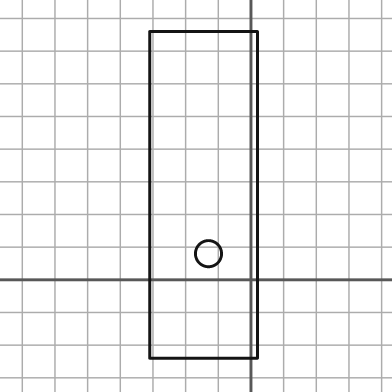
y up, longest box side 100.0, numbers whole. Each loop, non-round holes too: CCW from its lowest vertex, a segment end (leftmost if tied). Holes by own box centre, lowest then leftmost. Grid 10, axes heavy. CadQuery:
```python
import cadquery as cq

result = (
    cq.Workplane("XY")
    .moveTo(-31.0, -24.0)
    .lineTo(2.0, -24.0)
    .lineTo(2.0, 76.0)
    .lineTo(-31.0, 76.0)
    .close()
    .moveTo(-13.0, 8.0)
    .circle(4.0)
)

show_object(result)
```